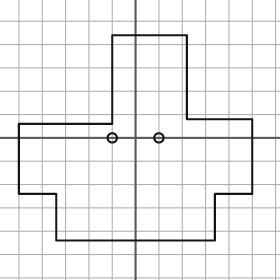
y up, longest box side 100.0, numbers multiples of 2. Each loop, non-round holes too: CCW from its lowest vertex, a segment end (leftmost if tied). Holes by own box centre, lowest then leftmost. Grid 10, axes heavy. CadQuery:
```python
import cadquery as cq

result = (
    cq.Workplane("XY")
    .moveTo(-34.0, -44.0)
    .lineTo(34.0, -44.0)
    .lineTo(34.0, -24.0)
    .lineTo(50.0, -24.0)
    .lineTo(50.0, 8.0)
    .lineTo(22.0, 8.0)
    .lineTo(22.0, 44.0)
    .lineTo(-10.0, 44.0)
    .lineTo(-10.0, 6.0)
    .lineTo(-50.0, 6.0)
    .lineTo(-50.0, -24.0)
    .lineTo(-34.0, -24.0)
    .close()
    .moveTo(-10.0, 0.0)
    .circle(2.0)
    .moveTo(10.0, 0.0)
    .circle(2.0)
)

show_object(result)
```